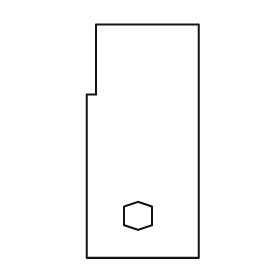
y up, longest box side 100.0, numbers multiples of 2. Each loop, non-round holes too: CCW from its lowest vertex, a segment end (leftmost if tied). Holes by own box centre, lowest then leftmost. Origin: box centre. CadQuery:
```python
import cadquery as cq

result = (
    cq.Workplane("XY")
    .moveTo(-24.0, -50.0)
    .lineTo(24.0, -50.0)
    .lineTo(24.0, 50.0)
    .lineTo(-20.0, 50.0)
    .lineTo(-20.0, 20.0)
    .lineTo(-24.0, 20.0)
    .close()
    .moveTo(-2.0, -38.0)
    .lineTo(4.0, -36.0)
    .lineTo(4.0, -28.0)
    .lineTo(-2.0, -26.0)
    .lineTo(-8.0, -28.0)
    .lineTo(-8.0, -36.0)
    .close()
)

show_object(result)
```